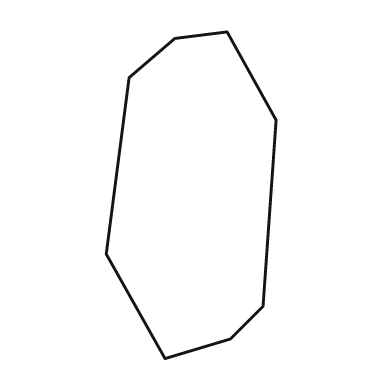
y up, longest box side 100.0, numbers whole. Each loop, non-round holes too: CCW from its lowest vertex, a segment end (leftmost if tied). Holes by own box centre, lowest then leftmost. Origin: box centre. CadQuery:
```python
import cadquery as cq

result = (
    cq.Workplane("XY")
    .moveTo(-8.0, -50.0)
    .lineTo(12.0, -44.0)
    .lineTo(22.0, -34.0)
    .lineTo(26.0, 23.0)
    .lineTo(11.0, 50.0)
    .lineTo(-5.0, 48.0)
    .lineTo(-19.0, 36.0)
    .lineTo(-26.0, -18.0)
    .close()
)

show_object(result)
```